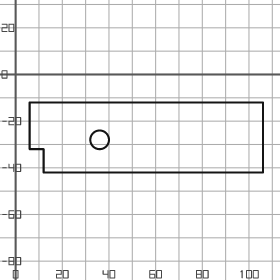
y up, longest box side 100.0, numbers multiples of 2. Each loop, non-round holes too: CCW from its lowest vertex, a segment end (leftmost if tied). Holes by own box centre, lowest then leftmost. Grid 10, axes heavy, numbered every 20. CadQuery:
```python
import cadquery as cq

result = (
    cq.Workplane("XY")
    .moveTo(12.0, -42.0)
    .lineTo(106.0, -42.0)
    .lineTo(106.0, -12.0)
    .lineTo(6.0, -12.0)
    .lineTo(6.0, -32.0)
    .lineTo(12.0, -32.0)
    .close()
    .moveTo(36.0, -28.0)
    .circle(4.0)
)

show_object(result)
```